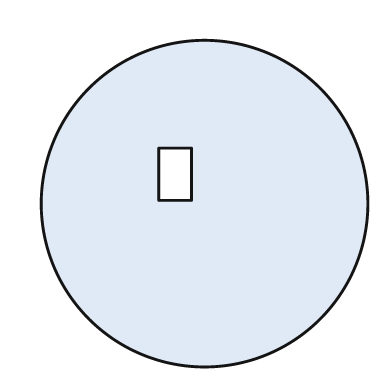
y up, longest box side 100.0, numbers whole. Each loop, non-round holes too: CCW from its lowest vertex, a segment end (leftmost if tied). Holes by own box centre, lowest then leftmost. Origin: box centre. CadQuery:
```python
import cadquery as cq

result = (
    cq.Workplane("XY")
    .moveTo(0.0, 0.0)
    .circle(50.0)
    .moveTo(-14.0, 1.0)
    .lineTo(-4.0, 1.0)
    .lineTo(-4.0, 17.0)
    .lineTo(-14.0, 17.0)
    .close()
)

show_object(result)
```